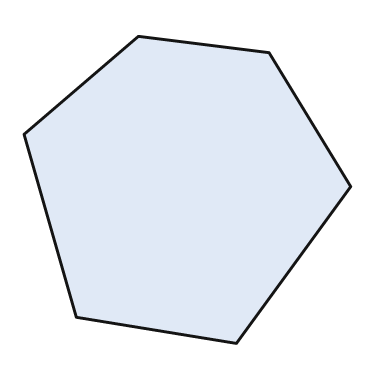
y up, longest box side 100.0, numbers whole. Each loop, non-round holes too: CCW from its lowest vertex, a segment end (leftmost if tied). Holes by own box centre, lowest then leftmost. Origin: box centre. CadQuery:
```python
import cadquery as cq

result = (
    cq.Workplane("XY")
    .moveTo(15.0, -47.0)
    .lineTo(50.0, 1.0)
    .lineTo(25.0, 42.0)
    .lineTo(-15.0, 47.0)
    .lineTo(-50.0, 17.0)
    .lineTo(-34.0, -39.0)
    .close()
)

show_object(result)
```